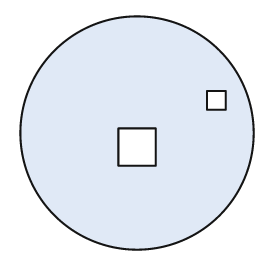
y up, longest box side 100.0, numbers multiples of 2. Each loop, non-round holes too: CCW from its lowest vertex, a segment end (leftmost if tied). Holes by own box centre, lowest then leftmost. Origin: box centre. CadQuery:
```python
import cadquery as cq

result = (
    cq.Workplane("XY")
    .moveTo(0.0, 0.0)
    .circle(50.0)
    .moveTo(-8.0, -14.0)
    .lineTo(8.0, -14.0)
    .lineTo(8.0, 2.0)
    .lineTo(-8.0, 2.0)
    .close()
    .moveTo(30.0, 10.0)
    .lineTo(38.0, 10.0)
    .lineTo(38.0, 18.0)
    .lineTo(30.0, 18.0)
    .close()
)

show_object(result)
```